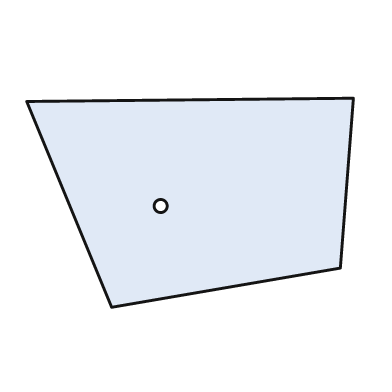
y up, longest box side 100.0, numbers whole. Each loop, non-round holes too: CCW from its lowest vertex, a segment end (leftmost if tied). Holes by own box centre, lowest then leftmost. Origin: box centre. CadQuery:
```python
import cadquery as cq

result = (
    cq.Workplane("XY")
    .moveTo(-24.0, -32.0)
    .lineTo(46.0, -20.0)
    .lineTo(50.0, 32.0)
    .lineTo(-50.0, 31.0)
    .close()
    .moveTo(-9.0, -1.0)
    .circle(2.0)
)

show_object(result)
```